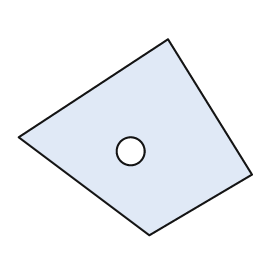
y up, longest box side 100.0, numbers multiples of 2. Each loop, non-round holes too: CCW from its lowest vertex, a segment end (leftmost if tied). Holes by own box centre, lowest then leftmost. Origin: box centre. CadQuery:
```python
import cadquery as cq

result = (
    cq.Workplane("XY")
    .moveTo(6.0, -42.0)
    .lineTo(50.0, -16.0)
    .lineTo(14.0, 42.0)
    .lineTo(-50.0, 0.0)
    .close()
    .moveTo(-2.0, -6.0)
    .circle(6.0)
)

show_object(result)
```